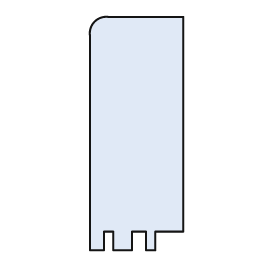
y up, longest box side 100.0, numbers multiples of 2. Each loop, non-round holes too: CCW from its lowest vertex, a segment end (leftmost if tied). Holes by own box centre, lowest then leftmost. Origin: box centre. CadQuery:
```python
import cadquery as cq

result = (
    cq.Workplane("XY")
    .moveTo(-20.0, -50.0)
    .lineTo(-14.0, -50.0)
    .lineTo(-14.0, -42.0)
    .lineTo(-10.0, -42.0)
    .lineTo(-10.0, -50.0)
    .lineTo(-2.0, -50.0)
    .lineTo(-2.0, -42.0)
    .lineTo(4.0, -42.0)
    .lineTo(4.0, -50.0)
    .lineTo(8.0, -50.0)
    .lineTo(8.0, -42.0)
    .lineTo(20.0, -42.0)
    .lineTo(20.0, 50.0)
    .lineTo(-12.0, 50.0)
    .threePointArc((-18.0, 48.0), (-20.0, 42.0))
    .close()
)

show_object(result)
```